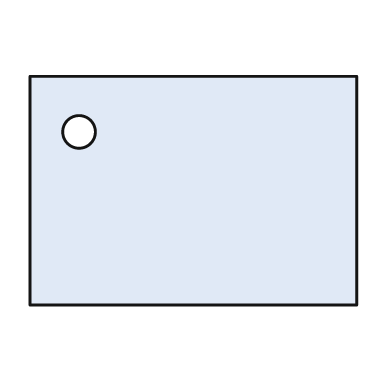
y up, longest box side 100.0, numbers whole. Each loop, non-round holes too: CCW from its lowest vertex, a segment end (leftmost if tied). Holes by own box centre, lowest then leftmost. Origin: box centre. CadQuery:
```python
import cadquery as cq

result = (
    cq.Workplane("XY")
    .moveTo(-50.0, -35.0)
    .lineTo(50.0, -35.0)
    .lineTo(50.0, 35.0)
    .lineTo(-50.0, 35.0)
    .close()
    .moveTo(-35.0, 18.0)
    .circle(5.0)
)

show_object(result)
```